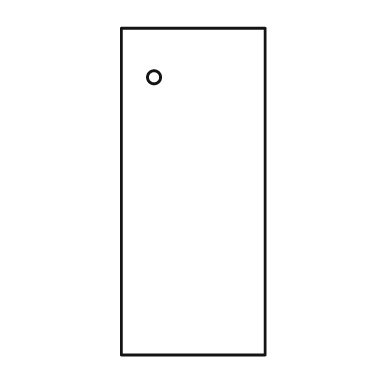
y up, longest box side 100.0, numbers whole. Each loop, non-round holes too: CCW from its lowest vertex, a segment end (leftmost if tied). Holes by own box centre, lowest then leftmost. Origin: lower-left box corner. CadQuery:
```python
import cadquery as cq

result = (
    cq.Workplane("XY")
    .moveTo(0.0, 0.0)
    .lineTo(44.0, 0.0)
    .lineTo(44.0, 100.0)
    .lineTo(0.0, 100.0)
    .close()
    .moveTo(10.0, 85.0)
    .circle(2.0)
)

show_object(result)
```